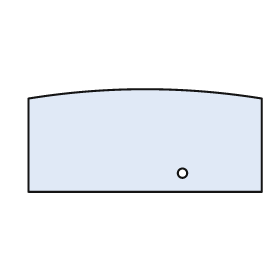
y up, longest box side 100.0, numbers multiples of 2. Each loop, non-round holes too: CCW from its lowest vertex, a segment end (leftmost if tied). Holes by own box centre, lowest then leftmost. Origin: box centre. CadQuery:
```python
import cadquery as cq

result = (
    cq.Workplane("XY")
    .moveTo(-50.0, -22.0)
    .lineTo(50.0, -22.0)
    .lineTo(50.0, 18.0)
    .threePointArc((0.0, 22.0), (-50.0, 18.0))
    .close()
    .moveTo(16.0, -14.0)
    .circle(2.0)
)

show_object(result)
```